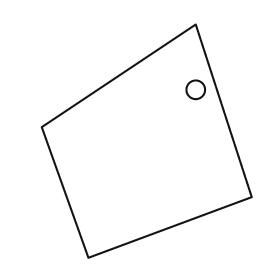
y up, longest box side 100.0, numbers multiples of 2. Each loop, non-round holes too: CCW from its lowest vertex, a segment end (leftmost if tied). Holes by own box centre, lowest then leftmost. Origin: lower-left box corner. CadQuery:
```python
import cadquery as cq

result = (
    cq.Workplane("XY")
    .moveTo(20.0, 0.0)
    .lineTo(90.0, 26.0)
    .lineTo(66.0, 100.0)
    .lineTo(0.0, 56.0)
    .close()
    .moveTo(66.0, 72.0)
    .circle(4.0)
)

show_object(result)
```